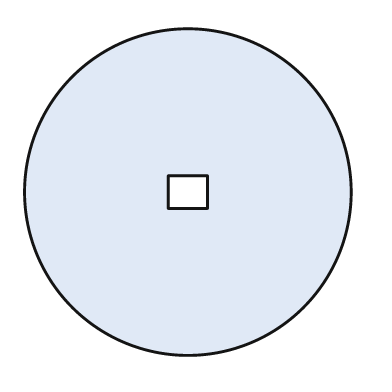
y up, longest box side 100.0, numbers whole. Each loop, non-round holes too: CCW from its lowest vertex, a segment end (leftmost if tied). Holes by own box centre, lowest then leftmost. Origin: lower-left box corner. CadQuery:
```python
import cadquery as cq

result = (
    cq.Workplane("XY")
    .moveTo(50.0, 50.0)
    .circle(50.0)
    .moveTo(44.0, 45.0)
    .lineTo(56.0, 45.0)
    .lineTo(56.0, 55.0)
    .lineTo(44.0, 55.0)
    .close()
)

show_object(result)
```